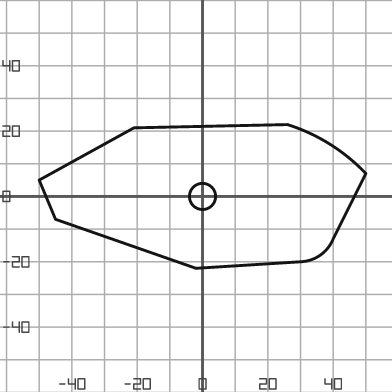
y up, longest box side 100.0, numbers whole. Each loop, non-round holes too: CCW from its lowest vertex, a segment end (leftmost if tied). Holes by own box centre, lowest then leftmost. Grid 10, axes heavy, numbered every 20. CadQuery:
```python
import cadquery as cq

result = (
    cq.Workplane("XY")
    .moveTo(-2.0, -22.0)
    .lineTo(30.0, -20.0)
    .threePointArc((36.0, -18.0), (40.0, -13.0))
    .lineTo(50.0, 7.0)
    .threePointArc((39.0, 16.0), (26.0, 22.0))
    .lineTo(-21.0, 21.0)
    .lineTo(-50.0, 5.0)
    .lineTo(-45.0, -7.0)
    .close()
    .moveTo(0.0, 0.0)
    .circle(4.0)
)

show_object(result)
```